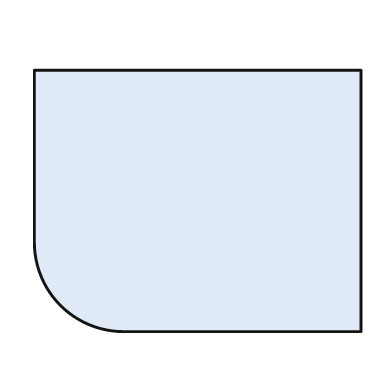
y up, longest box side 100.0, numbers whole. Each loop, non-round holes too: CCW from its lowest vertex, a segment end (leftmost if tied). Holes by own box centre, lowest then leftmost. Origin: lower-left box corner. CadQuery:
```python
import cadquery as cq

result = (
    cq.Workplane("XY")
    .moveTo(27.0, 0.0)
    .lineTo(100.0, 0.0)
    .lineTo(100.0, 80.0)
    .lineTo(0.0, 80.0)
    .lineTo(0.0, 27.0)
    .threePointArc((8.0, 8.0), (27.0, 0.0))
    .close()
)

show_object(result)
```